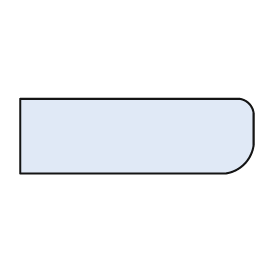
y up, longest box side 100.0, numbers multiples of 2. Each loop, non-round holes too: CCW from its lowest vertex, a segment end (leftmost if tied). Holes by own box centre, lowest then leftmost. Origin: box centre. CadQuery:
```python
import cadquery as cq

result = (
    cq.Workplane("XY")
    .moveTo(-50.0, -16.0)
    .lineTo(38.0, -16.0)
    .threePointArc((46.0, -12.0), (50.0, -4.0))
    .lineTo(50.0, 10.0)
    .threePointArc((48.0, 14.0), (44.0, 16.0))
    .lineTo(-50.0, 16.0)
    .close()
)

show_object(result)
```